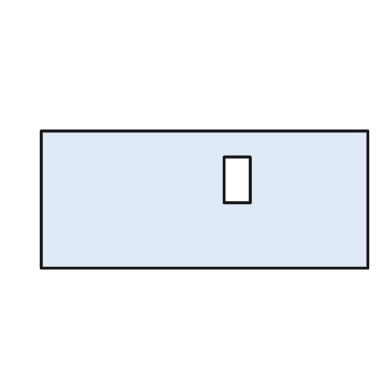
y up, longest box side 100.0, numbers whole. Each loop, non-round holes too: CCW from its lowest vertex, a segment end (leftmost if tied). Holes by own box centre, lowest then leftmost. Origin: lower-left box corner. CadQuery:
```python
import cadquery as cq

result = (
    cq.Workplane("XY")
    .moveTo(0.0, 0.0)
    .lineTo(100.0, 0.0)
    .lineTo(100.0, 42.0)
    .lineTo(0.0, 42.0)
    .close()
    .moveTo(56.0, 20.0)
    .lineTo(64.0, 20.0)
    .lineTo(64.0, 34.0)
    .lineTo(56.0, 34.0)
    .close()
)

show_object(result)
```